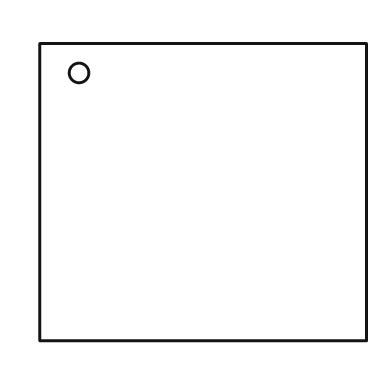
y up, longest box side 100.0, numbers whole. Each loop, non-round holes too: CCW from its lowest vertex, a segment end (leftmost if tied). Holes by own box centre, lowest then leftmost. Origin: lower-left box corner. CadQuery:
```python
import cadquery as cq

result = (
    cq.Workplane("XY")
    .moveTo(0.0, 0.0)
    .lineTo(100.0, 0.0)
    .lineTo(100.0, 91.0)
    .lineTo(0.0, 91.0)
    .close()
    .moveTo(12.0, 82.0)
    .circle(3.0)
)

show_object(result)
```